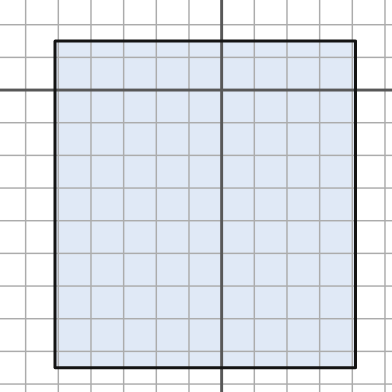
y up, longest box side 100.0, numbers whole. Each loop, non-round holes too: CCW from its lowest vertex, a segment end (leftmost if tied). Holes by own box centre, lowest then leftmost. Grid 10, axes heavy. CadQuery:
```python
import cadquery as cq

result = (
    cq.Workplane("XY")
    .moveTo(-51.0, -85.0)
    .lineTo(41.0, -85.0)
    .lineTo(41.0, 15.0)
    .lineTo(-51.0, 15.0)
    .close()
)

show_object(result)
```